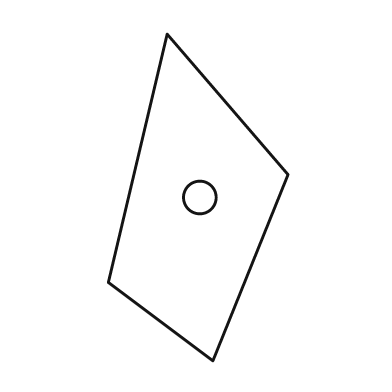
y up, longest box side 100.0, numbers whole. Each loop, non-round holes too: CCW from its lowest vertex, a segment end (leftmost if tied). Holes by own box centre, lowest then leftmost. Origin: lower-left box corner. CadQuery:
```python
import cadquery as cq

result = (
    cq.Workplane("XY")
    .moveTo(32.0, 0.0)
    .lineTo(55.0, 57.0)
    .lineTo(18.0, 100.0)
    .lineTo(0.0, 24.0)
    .close()
    .moveTo(28.0, 50.0)
    .circle(5.0)
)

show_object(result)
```